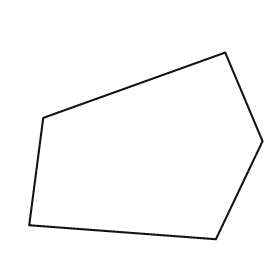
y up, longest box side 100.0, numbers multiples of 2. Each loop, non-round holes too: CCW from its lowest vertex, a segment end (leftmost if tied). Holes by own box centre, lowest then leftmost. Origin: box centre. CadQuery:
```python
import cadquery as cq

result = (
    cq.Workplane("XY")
    .moveTo(30.0, -40.0)
    .lineTo(50.0, 2.0)
    .lineTo(34.0, 40.0)
    .lineTo(-44.0, 12.0)
    .lineTo(-50.0, -34.0)
    .close()
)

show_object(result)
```